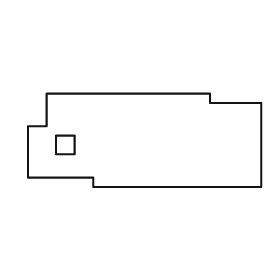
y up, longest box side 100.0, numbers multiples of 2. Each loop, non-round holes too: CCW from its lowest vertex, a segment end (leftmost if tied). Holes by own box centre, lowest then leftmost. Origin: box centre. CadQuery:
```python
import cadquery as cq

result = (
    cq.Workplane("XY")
    .moveTo(-22.0, -20.0)
    .lineTo(50.0, -20.0)
    .lineTo(50.0, 16.0)
    .lineTo(28.0, 16.0)
    .lineTo(28.0, 20.0)
    .lineTo(-42.0, 20.0)
    .lineTo(-42.0, 6.0)
    .lineTo(-50.0, 6.0)
    .lineTo(-50.0, -16.0)
    .lineTo(-22.0, -16.0)
    .close()
    .moveTo(-38.0, -6.0)
    .lineTo(-30.0, -6.0)
    .lineTo(-30.0, 2.0)
    .lineTo(-38.0, 2.0)
    .close()
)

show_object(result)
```